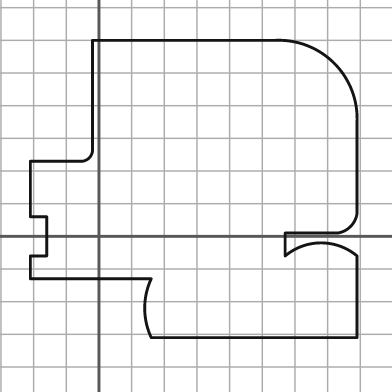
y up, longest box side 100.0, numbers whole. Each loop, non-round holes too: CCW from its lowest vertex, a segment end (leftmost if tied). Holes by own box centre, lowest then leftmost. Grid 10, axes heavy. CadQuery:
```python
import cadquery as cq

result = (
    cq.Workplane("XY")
    .moveTo(16.0, -31.0)
    .lineTo(79.0, -31.0)
    .lineTo(79.0, -6.0)
    .threePointArc((68.0, -2.0), (57.0, -6.0))
    .lineTo(57.0, 1.0)
    .lineTo(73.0, 1.0)
    .threePointArc((77.0, 3.0), (79.0, 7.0))
    .lineTo(79.0, 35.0)
    .threePointArc((72.0, 53.0), (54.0, 60.0))
    .lineTo(-2.0, 60.0)
    .lineTo(-2.0, 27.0)
    .threePointArc((-3.0, 24.0), (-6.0, 23.0))
    .lineTo(-21.0, 23.0)
    .lineTo(-21.0, 6.0)
    .lineTo(-16.0, 6.0)
    .lineTo(-16.0, -6.0)
    .lineTo(-21.0, -6.0)
    .lineTo(-21.0, -13.0)
    .lineTo(16.0, -13.0)
    .threePointArc((14.0, -22.0), (16.0, -31.0))
    .close()
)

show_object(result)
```